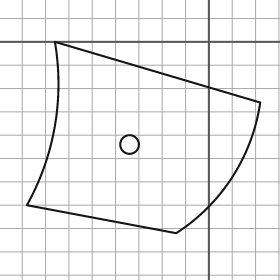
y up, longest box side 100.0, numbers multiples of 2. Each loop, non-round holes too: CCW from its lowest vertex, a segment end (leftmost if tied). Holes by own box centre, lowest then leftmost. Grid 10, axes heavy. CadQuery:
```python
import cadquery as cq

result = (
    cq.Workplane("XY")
    .moveTo(-14.0, -82.0)
    .threePointArc((10.0, -58.0), (22.0, -26.0))
    .lineTo(-66.0, 0.0)
    .threePointArc((-66.0, -36.0), (-78.0, -70.0))
    .close()
    .moveTo(-34.0, -44.0)
    .circle(4.0)
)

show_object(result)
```